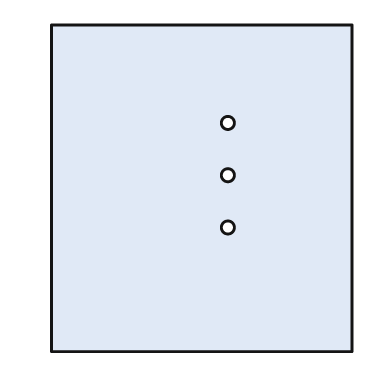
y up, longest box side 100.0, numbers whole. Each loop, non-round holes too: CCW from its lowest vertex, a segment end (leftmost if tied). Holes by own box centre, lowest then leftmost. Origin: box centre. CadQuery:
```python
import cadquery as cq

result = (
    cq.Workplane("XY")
    .moveTo(-46.0, -50.0)
    .lineTo(46.0, -50.0)
    .lineTo(46.0, 50.0)
    .lineTo(-46.0, 50.0)
    .close()
    .moveTo(8.0, -12.0)
    .circle(2.0)
    .moveTo(8.0, 4.0)
    .circle(2.0)
    .moveTo(8.0, 20.0)
    .circle(2.0)
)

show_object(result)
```